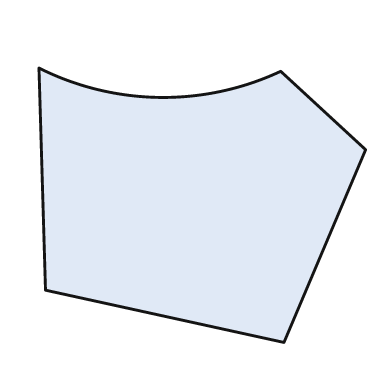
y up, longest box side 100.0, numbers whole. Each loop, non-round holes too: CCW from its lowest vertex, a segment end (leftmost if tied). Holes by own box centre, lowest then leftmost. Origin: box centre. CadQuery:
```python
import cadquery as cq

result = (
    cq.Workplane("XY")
    .moveTo(25.0, -42.0)
    .lineTo(50.0, 17.0)
    .lineTo(24.0, 41.0)
    .threePointArc((-13.0, 33.0), (-50.0, 42.0))
    .lineTo(-48.0, -26.0)
    .close()
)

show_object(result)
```